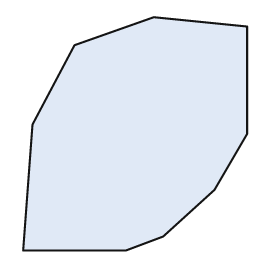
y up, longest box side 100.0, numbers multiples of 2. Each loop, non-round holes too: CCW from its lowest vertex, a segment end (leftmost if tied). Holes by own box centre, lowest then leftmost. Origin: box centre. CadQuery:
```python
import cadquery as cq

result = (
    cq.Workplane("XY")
    .moveTo(-48.0, -50.0)
    .lineTo(-4.0, -50.0)
    .lineTo(12.0, -44.0)
    .lineTo(34.0, -24.0)
    .lineTo(48.0, 0.0)
    .lineTo(48.0, 46.0)
    .lineTo(8.0, 50.0)
    .lineTo(-26.0, 38.0)
    .lineTo(-44.0, 4.0)
    .close()
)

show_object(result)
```